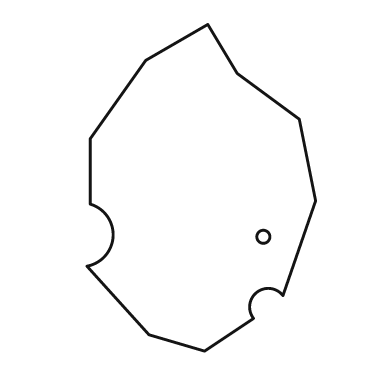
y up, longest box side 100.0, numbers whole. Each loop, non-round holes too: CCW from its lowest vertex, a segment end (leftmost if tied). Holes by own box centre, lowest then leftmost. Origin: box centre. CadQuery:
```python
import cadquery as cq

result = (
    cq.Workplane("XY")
    .moveTo(1.0, -50.0)
    .lineTo(16.0, -40.0)
    .threePointArc((17.0, -32.0), (25.0, -33.0))
    .lineTo(35.0, -4.0)
    .lineTo(30.0, 21.0)
    .lineTo(11.0, 35.0)
    .lineTo(2.0, 50.0)
    .lineTo(-17.0, 39.0)
    .lineTo(-34.0, 15.0)
    .lineTo(-34.0, -5.0)
    .threePointArc((-27.0, -15.0), (-35.0, -24.0))
    .lineTo(-16.0, -45.0)
    .close()
    .moveTo(19.0, -15.0)
    .circle(2.0)
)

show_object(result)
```